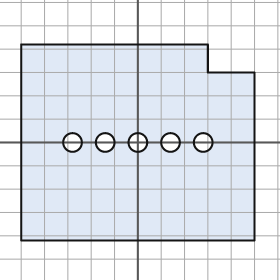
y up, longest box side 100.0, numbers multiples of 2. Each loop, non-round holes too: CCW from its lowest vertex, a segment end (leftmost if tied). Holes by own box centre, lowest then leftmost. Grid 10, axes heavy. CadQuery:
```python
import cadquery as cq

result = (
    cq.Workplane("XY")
    .moveTo(-50.0, -42.0)
    .lineTo(50.0, -42.0)
    .lineTo(50.0, 30.0)
    .lineTo(30.0, 30.0)
    .lineTo(30.0, 42.0)
    .lineTo(-50.0, 42.0)
    .close()
    .moveTo(-28.0, 0.0)
    .circle(4.0)
    .moveTo(-14.0, 0.0)
    .circle(4.0)
    .moveTo(0.0, 0.0)
    .circle(4.0)
    .moveTo(14.0, 0.0)
    .circle(4.0)
    .moveTo(28.0, 0.0)
    .circle(4.0)
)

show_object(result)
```